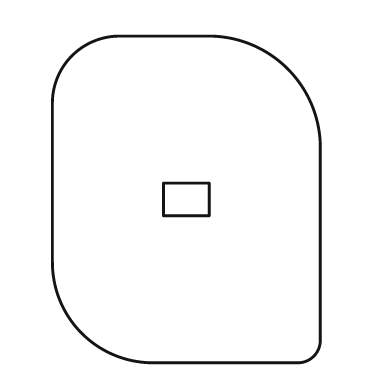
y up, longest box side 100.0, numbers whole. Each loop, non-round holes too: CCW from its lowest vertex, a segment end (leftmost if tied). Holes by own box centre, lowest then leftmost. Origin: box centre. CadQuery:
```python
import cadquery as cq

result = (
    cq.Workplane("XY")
    .moveTo(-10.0, -50.0)
    .lineTo(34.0, -50.0)
    .threePointArc((39.0, -48.0), (41.0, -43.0))
    .lineTo(41.0, 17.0)
    .threePointArc((31.0, 40.0), (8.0, 50.0))
    .lineTo(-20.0, 50.0)
    .threePointArc((-35.0, 44.0), (-41.0, 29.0))
    .lineTo(-41.0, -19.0)
    .threePointArc((-32.0, -41.0), (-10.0, -50.0))
    .close()
    .moveTo(-7.0, -5.0)
    .lineTo(7.0, -5.0)
    .lineTo(7.0, 5.0)
    .lineTo(-7.0, 5.0)
    .close()
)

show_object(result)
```